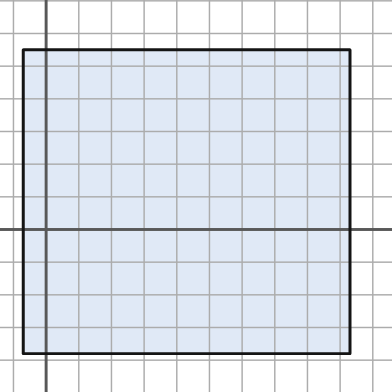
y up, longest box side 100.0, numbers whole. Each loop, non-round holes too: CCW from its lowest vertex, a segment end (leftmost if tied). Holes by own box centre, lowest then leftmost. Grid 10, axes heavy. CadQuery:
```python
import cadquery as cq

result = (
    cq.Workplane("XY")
    .moveTo(-7.0, -38.0)
    .lineTo(93.0, -38.0)
    .lineTo(93.0, 55.0)
    .lineTo(-7.0, 55.0)
    .close()
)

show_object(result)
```